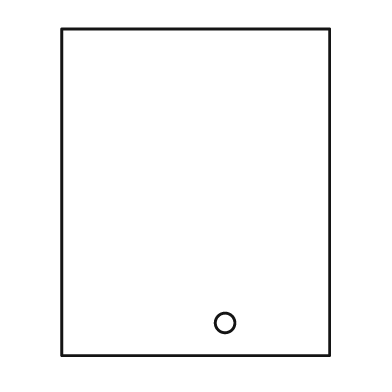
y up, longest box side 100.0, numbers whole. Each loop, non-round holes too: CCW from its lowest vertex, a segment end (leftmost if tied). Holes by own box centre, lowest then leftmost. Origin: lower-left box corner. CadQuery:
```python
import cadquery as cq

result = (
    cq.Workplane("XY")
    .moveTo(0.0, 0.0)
    .lineTo(82.0, 0.0)
    .lineTo(82.0, 100.0)
    .lineTo(0.0, 100.0)
    .close()
    .moveTo(50.0, 10.0)
    .circle(3.0)
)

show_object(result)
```